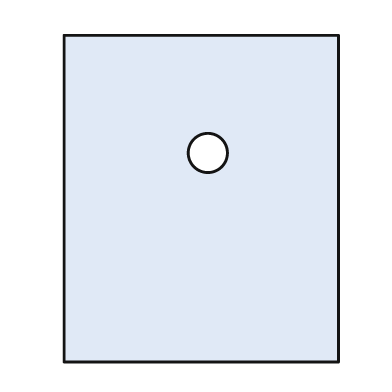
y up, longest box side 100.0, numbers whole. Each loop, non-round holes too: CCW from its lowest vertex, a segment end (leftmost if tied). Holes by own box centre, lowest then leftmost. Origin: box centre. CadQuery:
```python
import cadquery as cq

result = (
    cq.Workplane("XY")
    .moveTo(-42.0, -50.0)
    .lineTo(42.0, -50.0)
    .lineTo(42.0, 50.0)
    .lineTo(-42.0, 50.0)
    .close()
    .moveTo(2.0, 14.0)
    .circle(6.0)
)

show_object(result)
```